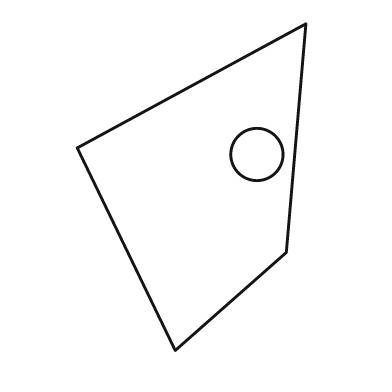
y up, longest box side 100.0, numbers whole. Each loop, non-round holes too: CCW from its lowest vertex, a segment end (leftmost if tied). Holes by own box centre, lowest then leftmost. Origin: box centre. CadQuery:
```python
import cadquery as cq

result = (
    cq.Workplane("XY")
    .moveTo(-5.0, -50.0)
    .lineTo(29.0, -20.0)
    .lineTo(35.0, 50.0)
    .lineTo(-35.0, 12.0)
    .close()
    .moveTo(20.0, 10.0)
    .circle(8.0)
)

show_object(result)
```